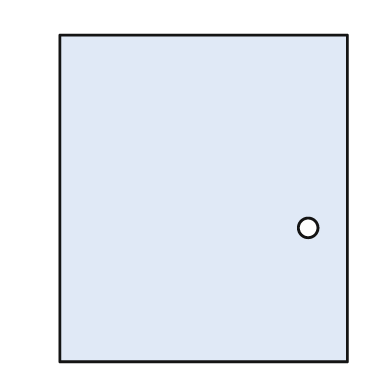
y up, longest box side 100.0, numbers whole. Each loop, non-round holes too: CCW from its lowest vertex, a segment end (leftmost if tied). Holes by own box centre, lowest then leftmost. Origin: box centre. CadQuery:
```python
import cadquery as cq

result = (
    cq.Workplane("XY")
    .moveTo(-44.0, -50.0)
    .lineTo(44.0, -50.0)
    .lineTo(44.0, 50.0)
    .lineTo(-44.0, 50.0)
    .close()
    .moveTo(32.0, -9.0)
    .circle(3.0)
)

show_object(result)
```